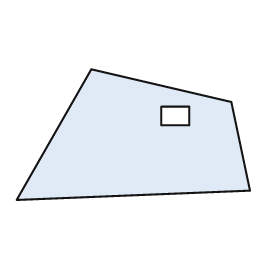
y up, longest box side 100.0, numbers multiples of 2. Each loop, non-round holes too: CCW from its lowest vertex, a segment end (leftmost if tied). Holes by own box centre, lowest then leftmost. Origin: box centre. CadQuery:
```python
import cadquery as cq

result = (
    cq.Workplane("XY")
    .moveTo(-50.0, -28.0)
    .lineTo(50.0, -24.0)
    .lineTo(42.0, 14.0)
    .lineTo(-18.0, 28.0)
    .close()
    .moveTo(12.0, 4.0)
    .lineTo(24.0, 4.0)
    .lineTo(24.0, 12.0)
    .lineTo(12.0, 12.0)
    .close()
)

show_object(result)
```